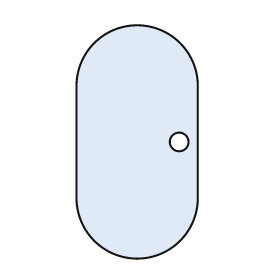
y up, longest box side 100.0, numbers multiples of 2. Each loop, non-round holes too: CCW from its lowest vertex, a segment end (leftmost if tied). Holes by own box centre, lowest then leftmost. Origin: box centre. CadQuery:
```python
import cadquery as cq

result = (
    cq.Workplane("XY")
    .moveTo(-26.0, -24.0)
    .threePointArc((0.0, -50.0), (26.0, -24.0))
    .lineTo(26.0, 24.0)
    .threePointArc((0.0, 50.0), (-26.0, 24.0))
    .close()
    .moveTo(18.0, 0.0)
    .circle(4.0)
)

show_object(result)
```